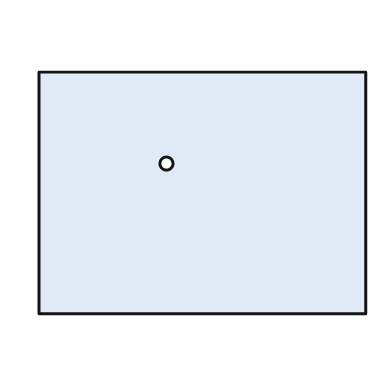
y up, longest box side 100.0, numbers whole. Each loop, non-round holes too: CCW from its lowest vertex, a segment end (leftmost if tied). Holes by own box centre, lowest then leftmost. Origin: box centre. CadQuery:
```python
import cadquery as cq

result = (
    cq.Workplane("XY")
    .moveTo(-50.0, -37.0)
    .lineTo(50.0, -37.0)
    .lineTo(50.0, 37.0)
    .lineTo(-50.0, 37.0)
    .close()
    .moveTo(-11.0, 9.0)
    .circle(2.0)
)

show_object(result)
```